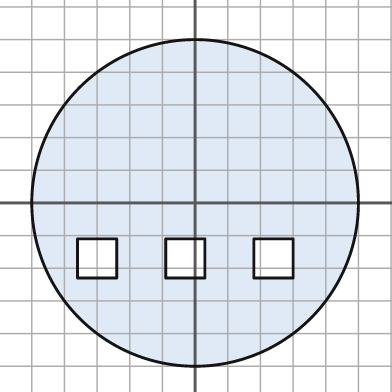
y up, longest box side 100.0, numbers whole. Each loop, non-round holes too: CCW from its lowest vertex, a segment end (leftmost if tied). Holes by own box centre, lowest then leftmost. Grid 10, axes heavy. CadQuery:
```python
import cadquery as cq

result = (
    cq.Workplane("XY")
    .moveTo(0.0, 0.0)
    .circle(50.0)
    .moveTo(-36.0, -23.0)
    .lineTo(-24.0, -23.0)
    .lineTo(-24.0, -11.0)
    .lineTo(-36.0, -11.0)
    .close()
    .moveTo(-9.0, -23.0)
    .lineTo(3.0, -23.0)
    .lineTo(3.0, -11.0)
    .lineTo(-9.0, -11.0)
    .close()
    .moveTo(18.0, -23.0)
    .lineTo(30.0, -23.0)
    .lineTo(30.0, -11.0)
    .lineTo(18.0, -11.0)
    .close()
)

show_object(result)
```